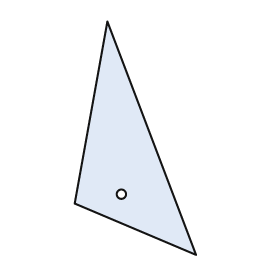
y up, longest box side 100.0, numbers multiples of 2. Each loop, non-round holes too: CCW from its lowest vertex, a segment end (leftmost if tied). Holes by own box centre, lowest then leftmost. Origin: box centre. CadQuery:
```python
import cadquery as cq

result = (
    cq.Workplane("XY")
    .moveTo(26.0, -50.0)
    .lineTo(-12.0, 50.0)
    .lineTo(-26.0, -28.0)
    .close()
    .moveTo(-6.0, -24.0)
    .circle(2.0)
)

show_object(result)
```